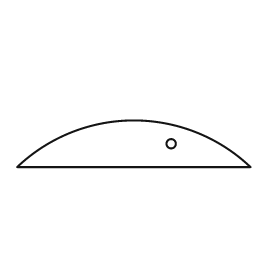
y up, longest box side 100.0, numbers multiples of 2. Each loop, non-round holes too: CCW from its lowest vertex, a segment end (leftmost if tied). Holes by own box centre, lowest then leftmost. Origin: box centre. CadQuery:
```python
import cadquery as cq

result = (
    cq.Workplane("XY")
    .moveTo(-50.0, -10.0)
    .lineTo(50.0, -10.0)
    .threePointArc((0.0, 10.0), (-50.0, -10.0))
    .close()
    .moveTo(16.0, 0.0)
    .circle(2.0)
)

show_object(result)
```